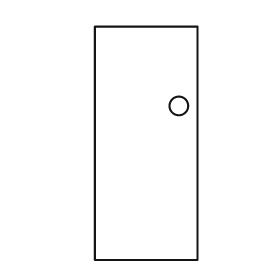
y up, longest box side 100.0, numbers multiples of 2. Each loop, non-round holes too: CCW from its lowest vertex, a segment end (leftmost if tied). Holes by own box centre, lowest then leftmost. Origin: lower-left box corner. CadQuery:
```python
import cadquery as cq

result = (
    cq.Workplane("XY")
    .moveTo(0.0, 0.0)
    .lineTo(44.0, 0.0)
    .lineTo(44.0, 100.0)
    .lineTo(0.0, 100.0)
    .close()
    .moveTo(36.0, 66.0)
    .circle(4.0)
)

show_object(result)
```